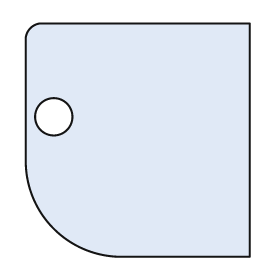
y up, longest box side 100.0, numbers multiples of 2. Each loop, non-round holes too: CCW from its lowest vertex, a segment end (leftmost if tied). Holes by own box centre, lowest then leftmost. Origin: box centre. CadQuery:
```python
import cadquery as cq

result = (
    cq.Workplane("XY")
    .moveTo(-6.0, -50.0)
    .lineTo(48.0, -50.0)
    .lineTo(48.0, 50.0)
    .lineTo(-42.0, 50.0)
    .threePointArc((-46.0, 48.0), (-48.0, 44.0))
    .lineTo(-48.0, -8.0)
    .threePointArc((-36.0, -38.0), (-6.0, -50.0))
    .close()
    .moveTo(-36.0, 10.0)
    .circle(8.0)
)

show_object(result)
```